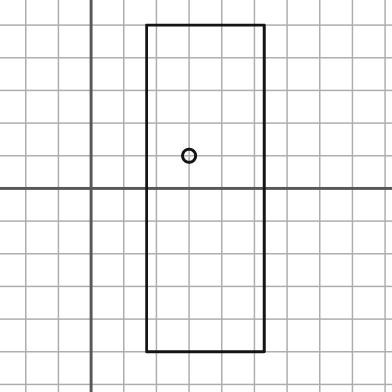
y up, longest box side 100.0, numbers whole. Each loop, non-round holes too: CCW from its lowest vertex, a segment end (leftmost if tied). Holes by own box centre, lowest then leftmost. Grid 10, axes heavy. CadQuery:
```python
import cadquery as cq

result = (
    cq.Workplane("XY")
    .moveTo(17.0, -50.0)
    .lineTo(53.0, -50.0)
    .lineTo(53.0, 50.0)
    .lineTo(17.0, 50.0)
    .close()
    .moveTo(30.0, 10.0)
    .circle(2.0)
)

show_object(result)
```